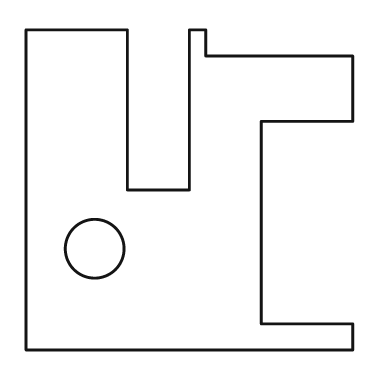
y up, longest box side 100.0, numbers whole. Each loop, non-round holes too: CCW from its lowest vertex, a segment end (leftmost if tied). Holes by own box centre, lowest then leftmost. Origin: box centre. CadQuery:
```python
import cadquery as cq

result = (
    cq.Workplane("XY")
    .moveTo(-50.0, -49.0)
    .lineTo(50.0, -49.0)
    .lineTo(50.0, -41.0)
    .lineTo(22.0, -41.0)
    .lineTo(22.0, 21.0)
    .lineTo(50.0, 21.0)
    .lineTo(50.0, 41.0)
    .lineTo(5.0, 41.0)
    .lineTo(5.0, 49.0)
    .lineTo(0.0, 49.0)
    .lineTo(0.0, 0.0)
    .lineTo(-19.0, 0.0)
    .lineTo(-19.0, 49.0)
    .lineTo(-50.0, 49.0)
    .close()
    .moveTo(-29.0, -18.0)
    .circle(9.0)
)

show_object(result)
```